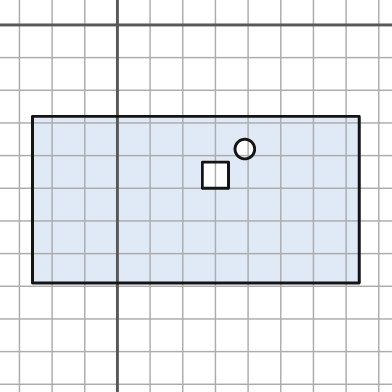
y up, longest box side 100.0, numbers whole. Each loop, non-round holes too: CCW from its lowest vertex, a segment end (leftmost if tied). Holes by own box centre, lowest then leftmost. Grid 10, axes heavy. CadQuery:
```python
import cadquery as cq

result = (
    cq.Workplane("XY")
    .moveTo(-26.0, -79.0)
    .lineTo(74.0, -79.0)
    .lineTo(74.0, -28.0)
    .lineTo(-26.0, -28.0)
    .close()
    .moveTo(26.0, -50.0)
    .lineTo(34.0, -50.0)
    .lineTo(34.0, -42.0)
    .lineTo(26.0, -42.0)
    .close()
    .moveTo(39.0, -38.0)
    .circle(3.0)
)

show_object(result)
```